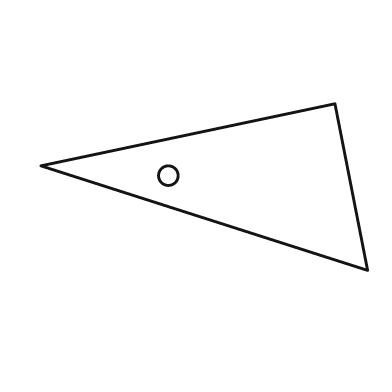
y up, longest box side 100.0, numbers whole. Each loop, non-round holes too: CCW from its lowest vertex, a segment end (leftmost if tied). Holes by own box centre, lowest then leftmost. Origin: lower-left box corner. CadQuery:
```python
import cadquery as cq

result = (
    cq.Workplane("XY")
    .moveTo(100.0, 0.0)
    .lineTo(90.0, 51.0)
    .lineTo(0.0, 32.0)
    .close()
    .moveTo(39.0, 29.0)
    .circle(3.0)
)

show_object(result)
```